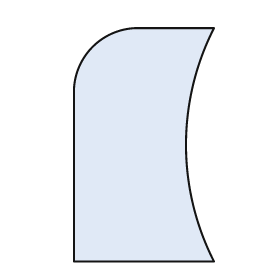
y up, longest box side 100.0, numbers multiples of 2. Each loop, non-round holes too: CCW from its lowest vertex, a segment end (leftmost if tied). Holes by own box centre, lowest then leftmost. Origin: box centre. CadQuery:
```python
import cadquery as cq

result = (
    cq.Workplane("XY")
    .moveTo(-30.0, -50.0)
    .lineTo(30.0, -50.0)
    .threePointArc((18.0, 0.0), (30.0, 50.0))
    .lineTo(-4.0, 50.0)
    .threePointArc((-22.0, 42.0), (-30.0, 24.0))
    .close()
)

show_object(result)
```